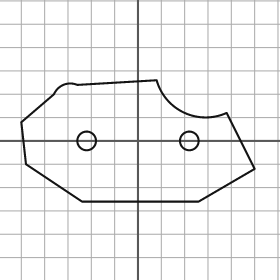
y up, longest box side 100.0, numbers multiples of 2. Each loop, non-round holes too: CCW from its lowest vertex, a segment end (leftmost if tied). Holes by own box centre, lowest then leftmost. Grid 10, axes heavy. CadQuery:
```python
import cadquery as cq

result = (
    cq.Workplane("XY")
    .moveTo(-24.0, -26.0)
    .lineTo(26.0, -26.0)
    .lineTo(50.0, -12.0)
    .lineTo(38.0, 12.0)
    .threePointArc((20.0, 12.0), (8.0, 26.0))
    .lineTo(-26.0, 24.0)
    .threePointArc((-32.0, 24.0), (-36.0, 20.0))
    .lineTo(-50.0, 8.0)
    .lineTo(-48.0, -10.0)
    .close()
    .moveTo(-22.0, 0.0)
    .circle(4.0)
    .moveTo(22.0, 0.0)
    .circle(4.0)
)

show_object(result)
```